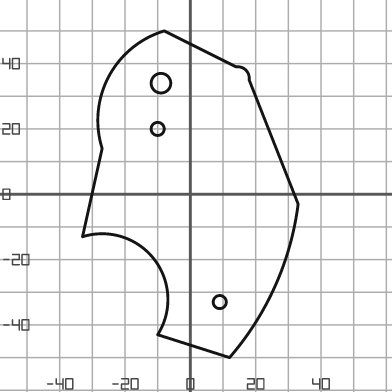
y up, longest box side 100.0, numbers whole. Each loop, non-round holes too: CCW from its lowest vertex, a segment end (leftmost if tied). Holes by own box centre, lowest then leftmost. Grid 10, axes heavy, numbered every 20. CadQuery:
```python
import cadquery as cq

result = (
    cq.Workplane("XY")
    .moveTo(12.0, -50.0)
    .threePointArc((26.0, -28.0), (33.0, -3.0))
    .lineTo(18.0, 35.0)
    .threePointArc((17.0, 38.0), (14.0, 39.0))
    .lineTo(-8.0, 50.0)
    .threePointArc((-25.0, 36.0), (-27.0, 14.0))
    .lineTo(-33.0, -13.0)
    .threePointArc((-11.0, -20.0), (-10.0, -43.0))
    .close()
    .moveTo(9.0, -33.0)
    .circle(2.0)
    .moveTo(-10.0, 20.0)
    .circle(2.0)
    .moveTo(-9.0, 34.0)
    .circle(3.0)
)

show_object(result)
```